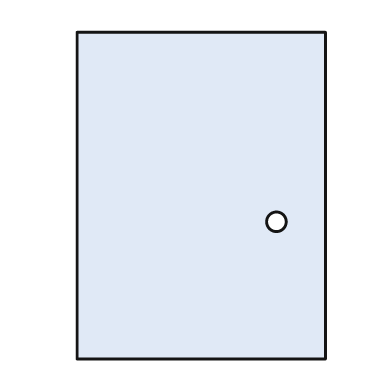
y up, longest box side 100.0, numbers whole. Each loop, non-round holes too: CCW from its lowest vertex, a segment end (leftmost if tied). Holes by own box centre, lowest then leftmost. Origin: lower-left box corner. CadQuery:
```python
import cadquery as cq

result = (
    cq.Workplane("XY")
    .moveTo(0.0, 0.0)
    .lineTo(76.0, 0.0)
    .lineTo(76.0, 100.0)
    .lineTo(0.0, 100.0)
    .close()
    .moveTo(61.0, 42.0)
    .circle(3.0)
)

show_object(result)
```